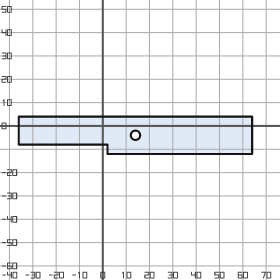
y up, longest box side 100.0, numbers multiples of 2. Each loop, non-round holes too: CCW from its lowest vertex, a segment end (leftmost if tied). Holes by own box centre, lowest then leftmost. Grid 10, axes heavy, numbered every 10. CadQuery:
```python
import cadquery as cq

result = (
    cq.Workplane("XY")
    .moveTo(2.0, -12.0)
    .lineTo(64.0, -12.0)
    .lineTo(64.0, 4.0)
    .lineTo(-36.0, 4.0)
    .lineTo(-36.0, -8.0)
    .lineTo(2.0, -8.0)
    .close()
    .moveTo(14.0, -4.0)
    .circle(2.0)
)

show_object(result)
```